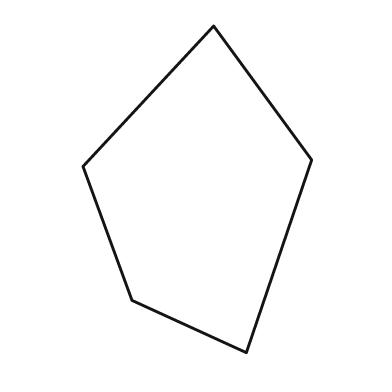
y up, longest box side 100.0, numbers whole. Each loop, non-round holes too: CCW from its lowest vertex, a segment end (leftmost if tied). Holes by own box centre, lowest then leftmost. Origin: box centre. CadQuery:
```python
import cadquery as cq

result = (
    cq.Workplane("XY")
    .moveTo(15.0, -50.0)
    .lineTo(35.0, 9.0)
    .lineTo(5.0, 50.0)
    .lineTo(-35.0, 7.0)
    .lineTo(-20.0, -34.0)
    .close()
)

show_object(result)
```